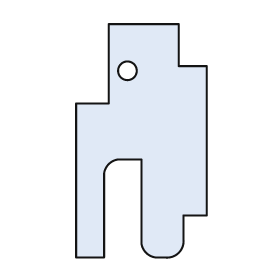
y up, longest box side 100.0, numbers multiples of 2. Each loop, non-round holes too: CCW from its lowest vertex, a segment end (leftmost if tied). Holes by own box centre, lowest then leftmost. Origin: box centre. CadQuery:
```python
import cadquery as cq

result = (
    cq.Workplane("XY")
    .moveTo(-28.0, -50.0)
    .lineTo(-16.0, -50.0)
    .lineTo(-16.0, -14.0)
    .threePointArc((-14.0, -10.0), (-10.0, -8.0))
    .lineTo(0.0, -8.0)
    .lineTo(0.0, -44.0)
    .threePointArc((2.0, -48.0), (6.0, -50.0))
    .lineTo(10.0, -50.0)
    .threePointArc((16.0, -48.0), (18.0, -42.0))
    .lineTo(18.0, -32.0)
    .lineTo(28.0, -32.0)
    .lineTo(28.0, 32.0)
    .lineTo(16.0, 32.0)
    .lineTo(16.0, 50.0)
    .lineTo(-14.0, 50.0)
    .lineTo(-14.0, 16.0)
    .lineTo(-28.0, 16.0)
    .close()
    .moveTo(-6.0, 30.0)
    .circle(4.0)
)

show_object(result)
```